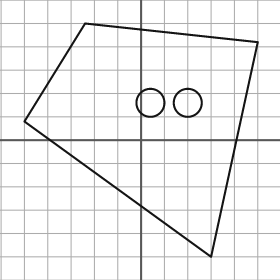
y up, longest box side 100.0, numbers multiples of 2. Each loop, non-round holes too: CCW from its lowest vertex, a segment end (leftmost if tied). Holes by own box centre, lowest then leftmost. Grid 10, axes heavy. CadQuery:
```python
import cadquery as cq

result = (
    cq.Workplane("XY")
    .moveTo(30.0, -50.0)
    .lineTo(50.0, 42.0)
    .lineTo(-24.0, 50.0)
    .lineTo(-50.0, 8.0)
    .close()
    .moveTo(4.0, 16.0)
    .circle(6.0)
    .moveTo(20.0, 16.0)
    .circle(6.0)
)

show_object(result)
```